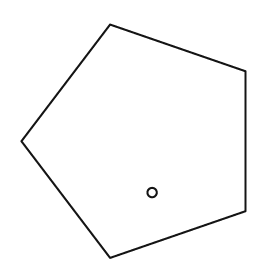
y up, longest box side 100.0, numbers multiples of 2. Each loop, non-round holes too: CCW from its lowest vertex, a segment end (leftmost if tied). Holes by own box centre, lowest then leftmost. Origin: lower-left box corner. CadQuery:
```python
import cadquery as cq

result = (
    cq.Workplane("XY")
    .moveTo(38.0, 0.0)
    .lineTo(96.0, 20.0)
    .lineTo(96.0, 80.0)
    .lineTo(38.0, 100.0)
    .lineTo(0.0, 50.0)
    .close()
    .moveTo(56.0, 28.0)
    .circle(2.0)
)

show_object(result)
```